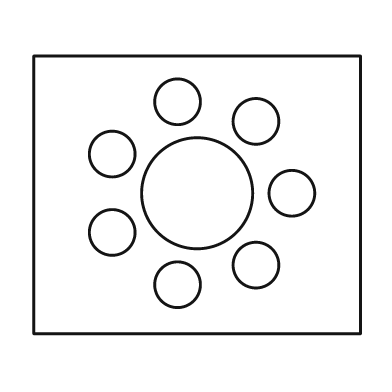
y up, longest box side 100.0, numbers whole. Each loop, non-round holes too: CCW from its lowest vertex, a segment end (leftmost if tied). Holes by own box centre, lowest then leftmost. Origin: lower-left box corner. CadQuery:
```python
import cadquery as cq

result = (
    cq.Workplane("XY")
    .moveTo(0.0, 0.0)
    .lineTo(100.0, 0.0)
    .lineTo(100.0, 85.0)
    .lineTo(0.0, 85.0)
    .close()
    .moveTo(44.0, 15.0)
    .circle(7.0)
    .moveTo(68.0, 21.0)
    .circle(7.0)
    .moveTo(24.0, 31.0)
    .circle(7.0)
    .moveTo(50.0, 43.0)
    .circle(17.0)
    .moveTo(79.0, 43.0)
    .circle(7.0)
    .moveTo(24.0, 55.0)
    .circle(7.0)
    .moveTo(68.0, 65.0)
    .circle(7.0)
    .moveTo(44.0, 71.0)
    .circle(7.0)
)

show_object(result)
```